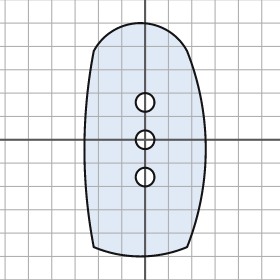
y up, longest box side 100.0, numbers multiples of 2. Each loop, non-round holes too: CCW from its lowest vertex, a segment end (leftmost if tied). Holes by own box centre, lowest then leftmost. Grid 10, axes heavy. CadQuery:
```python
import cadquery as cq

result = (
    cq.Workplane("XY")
    .moveTo(-22.0, -46.0)
    .threePointArc((-2.0, -50.0), (18.0, -46.0))
    .threePointArc((26.0, -4.0), (18.0, 38.0))
    .threePointArc((-2.0, 50.0), (-22.0, 38.0))
    .threePointArc((-26.0, -4.0), (-22.0, -46.0))
    .close()
    .moveTo(0.0, -16.0)
    .circle(4.0)
    .moveTo(0.0, 0.0)
    .circle(4.0)
    .moveTo(0.0, 16.0)
    .circle(4.0)
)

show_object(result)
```